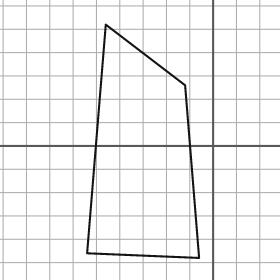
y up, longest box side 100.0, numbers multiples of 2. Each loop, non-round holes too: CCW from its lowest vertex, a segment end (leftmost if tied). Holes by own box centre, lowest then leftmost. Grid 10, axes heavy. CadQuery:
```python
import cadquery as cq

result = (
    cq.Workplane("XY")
    .moveTo(-6.0, -48.0)
    .lineTo(-12.0, 26.0)
    .lineTo(-46.0, 52.0)
    .lineTo(-54.0, -46.0)
    .close()
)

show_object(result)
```